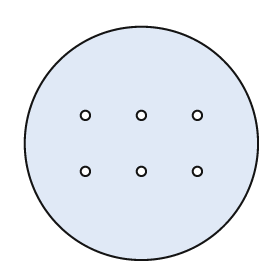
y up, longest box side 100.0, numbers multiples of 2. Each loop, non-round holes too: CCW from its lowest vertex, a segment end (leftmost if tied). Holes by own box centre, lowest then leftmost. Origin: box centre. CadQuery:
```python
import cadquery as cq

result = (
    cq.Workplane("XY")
    .moveTo(0.0, 0.0)
    .circle(50.0)
    .moveTo(-24.0, -12.0)
    .circle(2.0)
    .moveTo(0.0, -12.0)
    .circle(2.0)
    .moveTo(24.0, -12.0)
    .circle(2.0)
    .moveTo(-24.0, 12.0)
    .circle(2.0)
    .moveTo(0.0, 12.0)
    .circle(2.0)
    .moveTo(24.0, 12.0)
    .circle(2.0)
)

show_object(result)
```